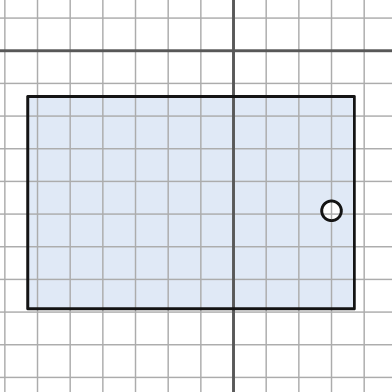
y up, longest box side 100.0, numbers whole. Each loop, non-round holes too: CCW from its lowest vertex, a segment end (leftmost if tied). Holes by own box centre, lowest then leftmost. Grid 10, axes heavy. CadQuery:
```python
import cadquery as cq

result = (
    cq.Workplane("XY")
    .moveTo(-63.0, -79.0)
    .lineTo(37.0, -79.0)
    .lineTo(37.0, -14.0)
    .lineTo(-63.0, -14.0)
    .close()
    .moveTo(30.0, -49.0)
    .circle(3.0)
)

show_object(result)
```